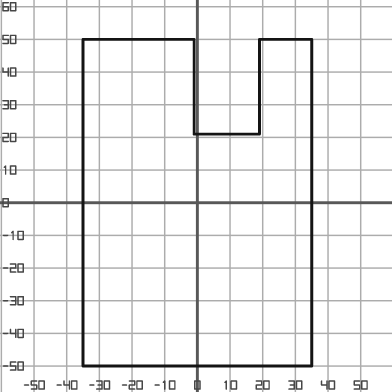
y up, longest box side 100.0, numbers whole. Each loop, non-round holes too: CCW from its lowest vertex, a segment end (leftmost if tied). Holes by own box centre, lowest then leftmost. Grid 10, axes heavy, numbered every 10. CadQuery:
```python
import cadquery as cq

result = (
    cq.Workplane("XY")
    .moveTo(-35.0, -50.0)
    .lineTo(35.0, -50.0)
    .lineTo(35.0, 50.0)
    .lineTo(19.0, 50.0)
    .lineTo(19.0, 21.0)
    .lineTo(-1.0, 21.0)
    .lineTo(-1.0, 50.0)
    .lineTo(-35.0, 50.0)
    .close()
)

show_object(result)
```